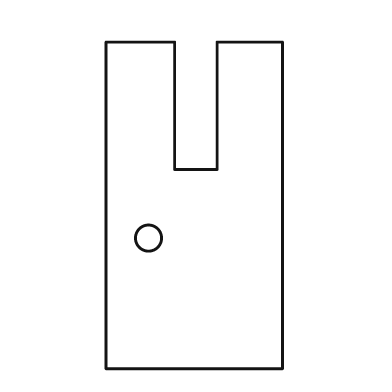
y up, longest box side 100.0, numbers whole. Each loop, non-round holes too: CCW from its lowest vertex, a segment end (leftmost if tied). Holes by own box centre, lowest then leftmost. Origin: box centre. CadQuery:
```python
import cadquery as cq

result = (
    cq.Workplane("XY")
    .moveTo(-27.0, -50.0)
    .lineTo(27.0, -50.0)
    .lineTo(27.0, 50.0)
    .lineTo(7.0, 50.0)
    .lineTo(7.0, 11.0)
    .lineTo(-6.0, 11.0)
    .lineTo(-6.0, 50.0)
    .lineTo(-27.0, 50.0)
    .close()
    .moveTo(-14.0, -10.0)
    .circle(4.0)
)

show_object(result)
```